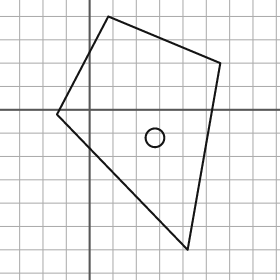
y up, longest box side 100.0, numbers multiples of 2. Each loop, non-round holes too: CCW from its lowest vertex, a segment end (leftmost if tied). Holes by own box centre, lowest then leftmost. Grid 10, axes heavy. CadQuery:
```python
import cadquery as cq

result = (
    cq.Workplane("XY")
    .moveTo(42.0, -60.0)
    .lineTo(56.0, 20.0)
    .lineTo(8.0, 40.0)
    .lineTo(-14.0, -2.0)
    .close()
    .moveTo(28.0, -12.0)
    .circle(4.0)
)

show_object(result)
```